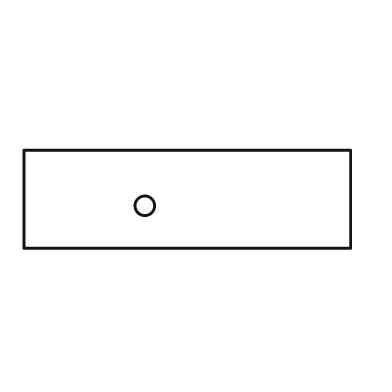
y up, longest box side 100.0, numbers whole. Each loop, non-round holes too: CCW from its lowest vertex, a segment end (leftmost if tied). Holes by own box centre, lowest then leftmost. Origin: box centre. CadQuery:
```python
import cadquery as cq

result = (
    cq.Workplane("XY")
    .moveTo(-50.0, -15.0)
    .lineTo(50.0, -15.0)
    .lineTo(50.0, 15.0)
    .lineTo(-50.0, 15.0)
    .close()
    .moveTo(-13.0, -2.0)
    .circle(3.0)
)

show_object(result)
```